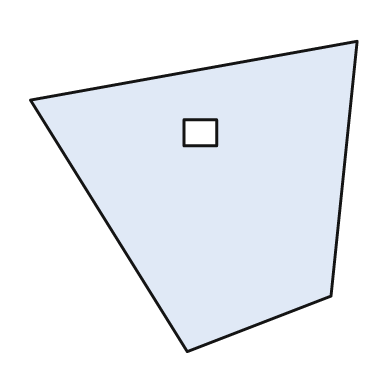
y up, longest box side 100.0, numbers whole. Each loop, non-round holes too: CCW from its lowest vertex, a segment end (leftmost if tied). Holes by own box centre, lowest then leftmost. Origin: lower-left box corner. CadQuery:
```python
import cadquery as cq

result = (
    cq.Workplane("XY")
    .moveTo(48.0, 0.0)
    .lineTo(92.0, 17.0)
    .lineTo(100.0, 95.0)
    .lineTo(0.0, 77.0)
    .close()
    .moveTo(47.0, 63.0)
    .lineTo(57.0, 63.0)
    .lineTo(57.0, 71.0)
    .lineTo(47.0, 71.0)
    .close()
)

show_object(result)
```